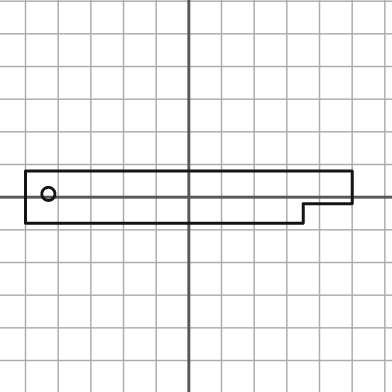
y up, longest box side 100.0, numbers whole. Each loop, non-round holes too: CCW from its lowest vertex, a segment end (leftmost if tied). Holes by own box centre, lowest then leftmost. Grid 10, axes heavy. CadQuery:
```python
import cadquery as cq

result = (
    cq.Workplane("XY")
    .moveTo(-50.0, -8.0)
    .lineTo(35.0, -8.0)
    .lineTo(35.0, -2.0)
    .lineTo(50.0, -2.0)
    .lineTo(50.0, 8.0)
    .lineTo(-50.0, 8.0)
    .close()
    .moveTo(-43.0, 1.0)
    .circle(2.0)
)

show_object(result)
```